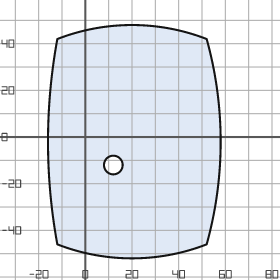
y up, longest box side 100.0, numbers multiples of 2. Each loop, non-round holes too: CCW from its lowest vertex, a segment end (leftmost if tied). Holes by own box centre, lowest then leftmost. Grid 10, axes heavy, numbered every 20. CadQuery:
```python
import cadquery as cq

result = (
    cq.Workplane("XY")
    .moveTo(-12.0, -46.0)
    .threePointArc((20.0, -52.0), (52.0, -46.0))
    .threePointArc((58.0, -2.0), (52.0, 42.0))
    .threePointArc((20.0, 48.0), (-12.0, 42.0))
    .threePointArc((-16.0, -2.0), (-12.0, -46.0))
    .close()
    .moveTo(12.0, -12.0)
    .circle(4.0)
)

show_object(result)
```